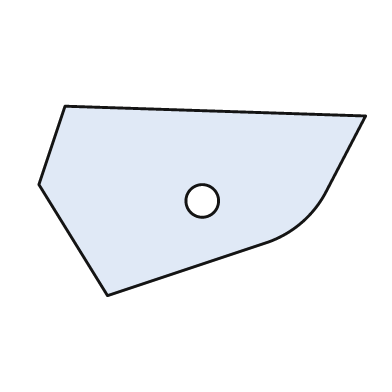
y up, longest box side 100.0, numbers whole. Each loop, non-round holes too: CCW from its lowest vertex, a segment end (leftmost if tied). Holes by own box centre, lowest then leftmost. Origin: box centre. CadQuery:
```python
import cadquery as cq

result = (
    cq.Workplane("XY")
    .moveTo(-29.0, -29.0)
    .lineTo(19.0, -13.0)
    .threePointArc((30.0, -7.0), (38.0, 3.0))
    .lineTo(50.0, 26.0)
    .lineTo(-42.0, 29.0)
    .lineTo(-50.0, 5.0)
    .close()
    .moveTo(0.0, 0.0)
    .circle(5.0)
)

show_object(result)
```